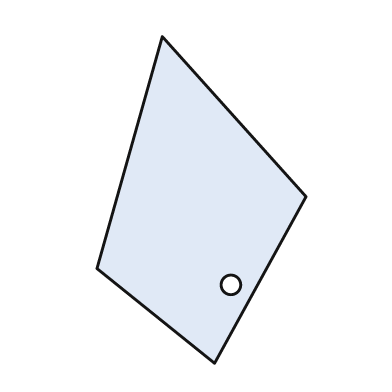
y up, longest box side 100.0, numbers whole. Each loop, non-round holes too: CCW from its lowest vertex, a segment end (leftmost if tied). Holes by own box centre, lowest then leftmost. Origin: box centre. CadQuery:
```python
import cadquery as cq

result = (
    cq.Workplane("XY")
    .moveTo(4.0, -50.0)
    .lineTo(32.0, 1.0)
    .lineTo(-12.0, 50.0)
    .lineTo(-32.0, -21.0)
    .close()
    .moveTo(9.0, -26.0)
    .circle(3.0)
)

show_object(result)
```